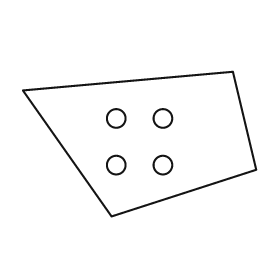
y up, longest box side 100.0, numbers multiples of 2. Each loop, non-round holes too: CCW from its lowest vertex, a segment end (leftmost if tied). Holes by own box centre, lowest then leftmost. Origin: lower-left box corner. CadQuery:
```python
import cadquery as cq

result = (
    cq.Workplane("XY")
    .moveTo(38.0, 0.0)
    .lineTo(100.0, 20.0)
    .lineTo(90.0, 62.0)
    .lineTo(0.0, 54.0)
    .close()
    .moveTo(40.0, 22.0)
    .circle(4.0)
    .moveTo(60.0, 22.0)
    .circle(4.0)
    .moveTo(40.0, 42.0)
    .circle(4.0)
    .moveTo(60.0, 42.0)
    .circle(4.0)
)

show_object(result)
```